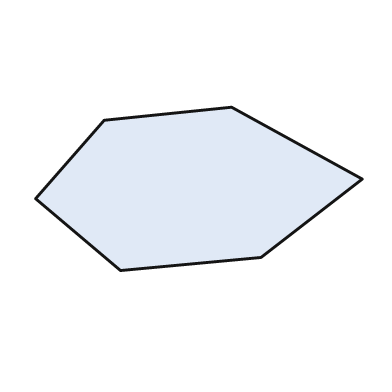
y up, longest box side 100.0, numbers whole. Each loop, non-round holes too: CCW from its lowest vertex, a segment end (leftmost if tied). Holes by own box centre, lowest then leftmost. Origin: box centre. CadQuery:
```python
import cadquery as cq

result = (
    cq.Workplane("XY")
    .moveTo(-24.0, -25.0)
    .lineTo(19.0, -21.0)
    .lineTo(50.0, 3.0)
    .lineTo(10.0, 25.0)
    .lineTo(-29.0, 21.0)
    .lineTo(-50.0, -3.0)
    .close()
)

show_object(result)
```